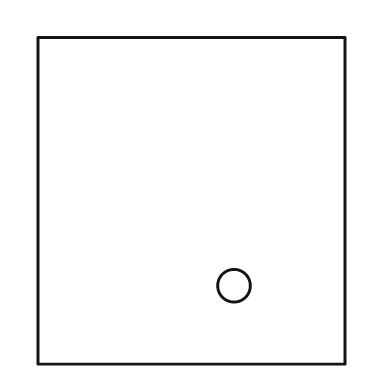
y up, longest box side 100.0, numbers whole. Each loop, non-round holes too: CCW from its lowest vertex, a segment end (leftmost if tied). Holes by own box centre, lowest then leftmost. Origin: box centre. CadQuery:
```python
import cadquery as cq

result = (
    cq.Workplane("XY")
    .moveTo(-47.0, -50.0)
    .lineTo(47.0, -50.0)
    .lineTo(47.0, 50.0)
    .lineTo(-47.0, 50.0)
    .close()
    .moveTo(13.0, -26.0)
    .circle(5.0)
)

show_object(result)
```